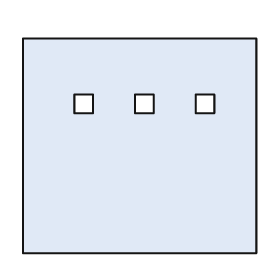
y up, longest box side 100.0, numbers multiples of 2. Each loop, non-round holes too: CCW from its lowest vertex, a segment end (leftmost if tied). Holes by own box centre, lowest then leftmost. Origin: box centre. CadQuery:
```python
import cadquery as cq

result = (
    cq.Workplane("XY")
    .moveTo(-50.0, -46.0)
    .lineTo(50.0, -46.0)
    .lineTo(50.0, 46.0)
    .lineTo(-50.0, 46.0)
    .close()
    .moveTo(-28.0, 14.0)
    .lineTo(-20.0, 14.0)
    .lineTo(-20.0, 22.0)
    .lineTo(-28.0, 22.0)
    .close()
    .moveTo(-2.0, 14.0)
    .lineTo(6.0, 14.0)
    .lineTo(6.0, 22.0)
    .lineTo(-2.0, 22.0)
    .close()
    .moveTo(24.0, 14.0)
    .lineTo(32.0, 14.0)
    .lineTo(32.0, 22.0)
    .lineTo(24.0, 22.0)
    .close()
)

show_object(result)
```